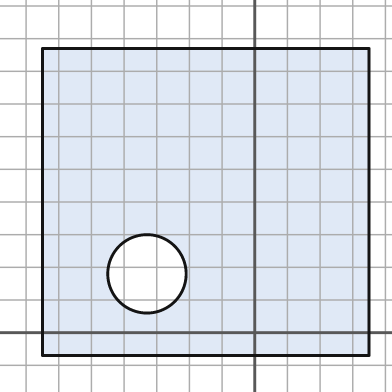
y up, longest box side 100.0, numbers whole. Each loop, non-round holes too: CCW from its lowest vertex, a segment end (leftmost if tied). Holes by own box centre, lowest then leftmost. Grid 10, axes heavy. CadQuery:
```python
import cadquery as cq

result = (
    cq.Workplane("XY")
    .moveTo(-65.0, -7.0)
    .lineTo(35.0, -7.0)
    .lineTo(35.0, 87.0)
    .lineTo(-65.0, 87.0)
    .close()
    .moveTo(-33.0, 18.0)
    .circle(12.0)
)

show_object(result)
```